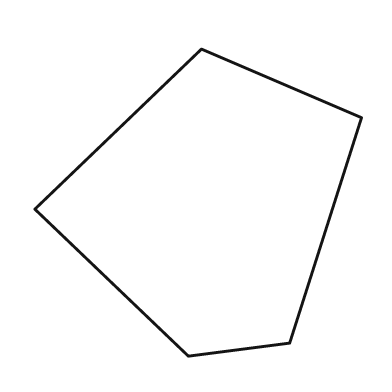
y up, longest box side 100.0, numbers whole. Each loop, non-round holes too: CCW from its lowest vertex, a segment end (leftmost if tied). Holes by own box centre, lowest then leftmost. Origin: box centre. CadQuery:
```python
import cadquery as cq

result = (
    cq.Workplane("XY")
    .moveTo(-3.0, -47.0)
    .lineTo(28.0, -43.0)
    .lineTo(50.0, 26.0)
    .lineTo(1.0, 47.0)
    .lineTo(-50.0, -2.0)
    .close()
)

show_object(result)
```